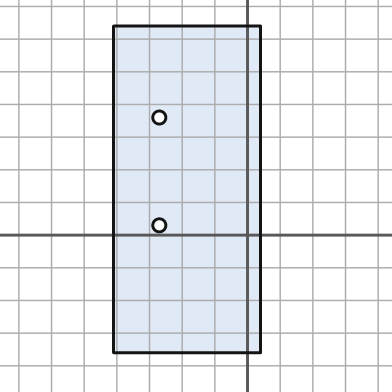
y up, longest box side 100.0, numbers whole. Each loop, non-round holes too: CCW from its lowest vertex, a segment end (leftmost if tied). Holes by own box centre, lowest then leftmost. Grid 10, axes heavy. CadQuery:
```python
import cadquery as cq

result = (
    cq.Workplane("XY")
    .moveTo(-41.0, -36.0)
    .lineTo(4.0, -36.0)
    .lineTo(4.0, 64.0)
    .lineTo(-41.0, 64.0)
    .close()
    .moveTo(-27.0, 3.0)
    .circle(2.0)
    .moveTo(-27.0, 36.0)
    .circle(2.0)
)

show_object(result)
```